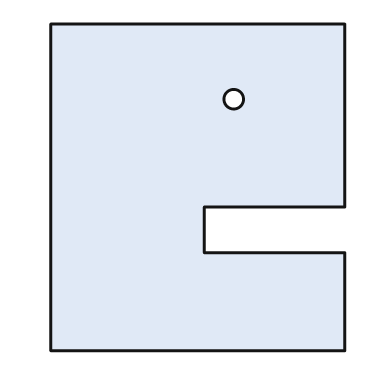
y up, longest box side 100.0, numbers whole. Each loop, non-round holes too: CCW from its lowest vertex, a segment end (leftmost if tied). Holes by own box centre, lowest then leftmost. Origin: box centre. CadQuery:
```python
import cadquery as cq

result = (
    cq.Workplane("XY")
    .moveTo(-45.0, -50.0)
    .lineTo(45.0, -50.0)
    .lineTo(45.0, -20.0)
    .lineTo(2.0, -20.0)
    .lineTo(2.0, -6.0)
    .lineTo(45.0, -6.0)
    .lineTo(45.0, 50.0)
    .lineTo(-45.0, 50.0)
    .close()
    .moveTo(11.0, 27.0)
    .circle(3.0)
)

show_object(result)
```